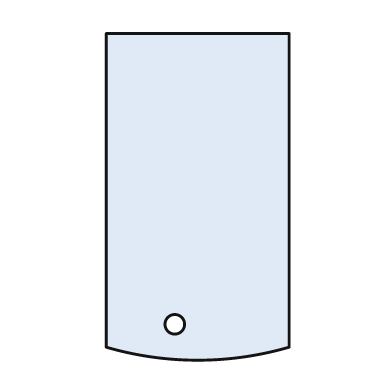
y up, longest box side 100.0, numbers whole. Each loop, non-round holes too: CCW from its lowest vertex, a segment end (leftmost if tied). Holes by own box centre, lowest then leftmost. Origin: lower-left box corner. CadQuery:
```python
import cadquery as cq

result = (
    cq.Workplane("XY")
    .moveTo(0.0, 4.0)
    .threePointArc((28.0, 0.0), (56.0, 4.0))
    .lineTo(56.0, 100.0)
    .lineTo(0.0, 100.0)
    .close()
    .moveTo(21.0, 11.0)
    .circle(3.0)
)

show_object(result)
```